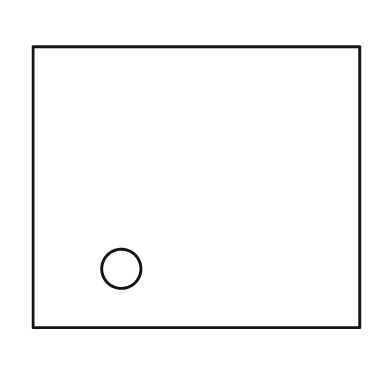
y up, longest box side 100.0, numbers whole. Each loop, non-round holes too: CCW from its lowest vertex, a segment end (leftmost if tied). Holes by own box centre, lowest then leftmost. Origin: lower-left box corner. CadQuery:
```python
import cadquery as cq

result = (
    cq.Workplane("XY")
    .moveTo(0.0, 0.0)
    .lineTo(100.0, 0.0)
    .lineTo(100.0, 86.0)
    .lineTo(0.0, 86.0)
    .close()
    .moveTo(27.0, 18.0)
    .circle(6.0)
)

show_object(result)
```